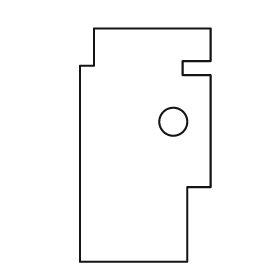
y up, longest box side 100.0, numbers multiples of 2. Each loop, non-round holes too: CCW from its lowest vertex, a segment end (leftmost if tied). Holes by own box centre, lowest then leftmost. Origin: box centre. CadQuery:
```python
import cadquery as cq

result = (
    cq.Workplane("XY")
    .moveTo(-28.0, -50.0)
    .lineTo(18.0, -50.0)
    .lineTo(18.0, -18.0)
    .lineTo(28.0, -18.0)
    .lineTo(28.0, 30.0)
    .lineTo(16.0, 30.0)
    .lineTo(16.0, 36.0)
    .lineTo(28.0, 36.0)
    .lineTo(28.0, 50.0)
    .lineTo(-22.0, 50.0)
    .lineTo(-22.0, 34.0)
    .lineTo(-28.0, 34.0)
    .close()
    .moveTo(12.0, 10.0)
    .circle(6.0)
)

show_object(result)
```